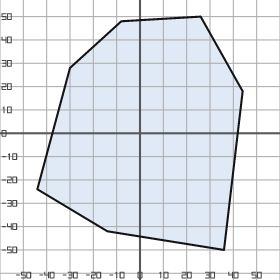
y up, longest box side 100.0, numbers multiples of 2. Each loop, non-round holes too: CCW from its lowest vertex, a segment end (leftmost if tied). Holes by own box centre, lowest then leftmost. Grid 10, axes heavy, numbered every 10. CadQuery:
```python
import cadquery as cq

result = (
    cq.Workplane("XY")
    .moveTo(36.0, -50.0)
    .lineTo(44.0, 18.0)
    .lineTo(26.0, 50.0)
    .lineTo(-8.0, 48.0)
    .lineTo(-30.0, 28.0)
    .lineTo(-44.0, -24.0)
    .lineTo(-14.0, -42.0)
    .close()
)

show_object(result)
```